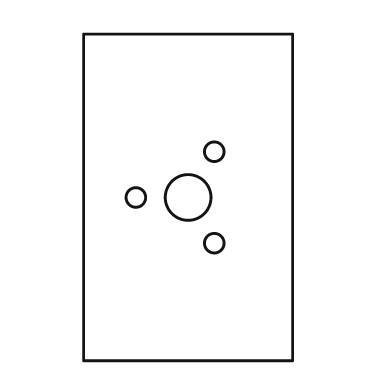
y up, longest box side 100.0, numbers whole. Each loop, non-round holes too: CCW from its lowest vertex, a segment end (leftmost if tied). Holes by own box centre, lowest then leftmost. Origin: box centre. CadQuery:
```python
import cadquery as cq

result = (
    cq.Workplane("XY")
    .moveTo(-32.0, -50.0)
    .lineTo(32.0, -50.0)
    .lineTo(32.0, 50.0)
    .lineTo(-32.0, 50.0)
    .close()
    .moveTo(8.0, -14.0)
    .circle(3.0)
    .moveTo(-16.0, 0.0)
    .circle(3.0)
    .moveTo(0.0, 0.0)
    .circle(7.0)
    .moveTo(8.0, 14.0)
    .circle(3.0)
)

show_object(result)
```